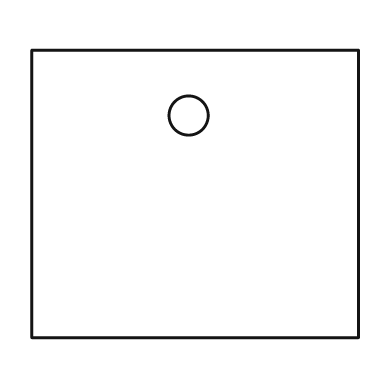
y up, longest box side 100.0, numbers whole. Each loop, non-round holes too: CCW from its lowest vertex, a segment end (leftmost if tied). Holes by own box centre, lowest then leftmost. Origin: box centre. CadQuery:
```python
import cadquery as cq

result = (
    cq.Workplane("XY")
    .moveTo(-50.0, -44.0)
    .lineTo(50.0, -44.0)
    .lineTo(50.0, 44.0)
    .lineTo(-50.0, 44.0)
    .close()
    .moveTo(-2.0, 24.0)
    .circle(6.0)
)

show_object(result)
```